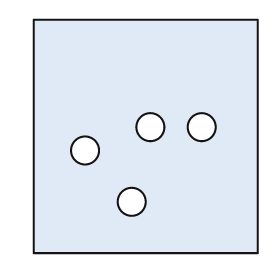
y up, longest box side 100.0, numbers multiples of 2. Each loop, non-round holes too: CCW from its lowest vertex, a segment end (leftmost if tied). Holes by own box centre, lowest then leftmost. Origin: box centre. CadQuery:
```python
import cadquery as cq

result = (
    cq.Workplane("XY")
    .moveTo(-48.0, -50.0)
    .lineTo(48.0, -50.0)
    .lineTo(48.0, 50.0)
    .lineTo(-48.0, 50.0)
    .close()
    .moveTo(-6.0, -28.0)
    .circle(6.0)
    .moveTo(-26.0, -6.0)
    .circle(6.0)
    .moveTo(2.0, 4.0)
    .circle(6.0)
    .moveTo(24.0, 4.0)
    .circle(6.0)
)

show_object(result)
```